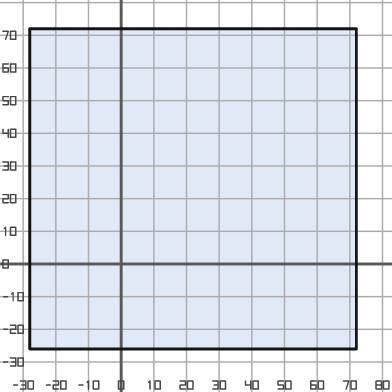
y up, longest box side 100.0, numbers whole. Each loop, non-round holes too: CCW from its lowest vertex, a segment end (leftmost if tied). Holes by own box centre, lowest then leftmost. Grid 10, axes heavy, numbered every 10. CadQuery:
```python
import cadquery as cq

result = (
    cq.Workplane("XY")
    .moveTo(-28.0, -26.0)
    .lineTo(72.0, -26.0)
    .lineTo(72.0, 72.0)
    .lineTo(-28.0, 72.0)
    .close()
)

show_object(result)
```